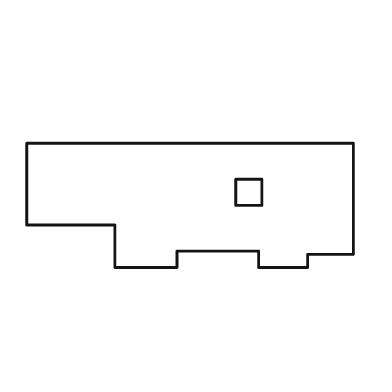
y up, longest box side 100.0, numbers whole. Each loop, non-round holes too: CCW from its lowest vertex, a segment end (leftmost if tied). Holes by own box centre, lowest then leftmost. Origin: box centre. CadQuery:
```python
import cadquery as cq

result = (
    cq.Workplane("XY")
    .moveTo(-23.0, -19.0)
    .lineTo(-4.0, -19.0)
    .lineTo(-4.0, -14.0)
    .lineTo(21.0, -14.0)
    .lineTo(21.0, -19.0)
    .lineTo(36.0, -19.0)
    .lineTo(36.0, -15.0)
    .lineTo(50.0, -15.0)
    .lineTo(50.0, 19.0)
    .lineTo(-50.0, 19.0)
    .lineTo(-50.0, -6.0)
    .lineTo(-23.0, -6.0)
    .close()
    .moveTo(14.0, 0.0)
    .lineTo(22.0, 0.0)
    .lineTo(22.0, 8.0)
    .lineTo(14.0, 8.0)
    .close()
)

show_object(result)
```